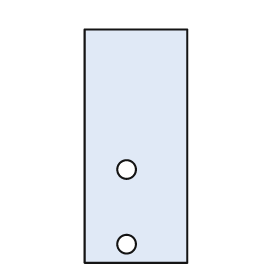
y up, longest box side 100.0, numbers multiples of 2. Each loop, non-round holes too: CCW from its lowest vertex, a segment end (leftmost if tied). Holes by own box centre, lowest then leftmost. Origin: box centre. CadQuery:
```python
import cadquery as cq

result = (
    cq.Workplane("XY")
    .moveTo(-22.0, -50.0)
    .lineTo(22.0, -50.0)
    .lineTo(22.0, 50.0)
    .lineTo(-22.0, 50.0)
    .close()
    .moveTo(-4.0, -42.0)
    .circle(4.0)
    .moveTo(-4.0, -10.0)
    .circle(4.0)
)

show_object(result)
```